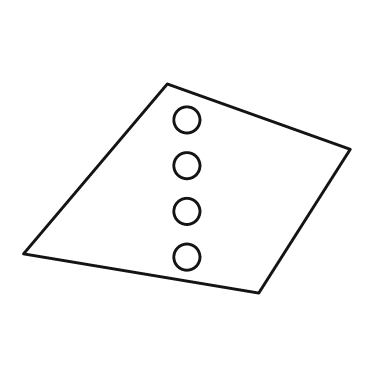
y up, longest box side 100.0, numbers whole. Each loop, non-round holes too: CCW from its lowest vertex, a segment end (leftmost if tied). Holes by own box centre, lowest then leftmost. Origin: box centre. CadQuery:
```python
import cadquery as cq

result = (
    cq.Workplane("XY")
    .moveTo(22.0, -32.0)
    .lineTo(50.0, 12.0)
    .lineTo(-6.0, 32.0)
    .lineTo(-50.0, -20.0)
    .close()
    .moveTo(0.0, -21.0)
    .circle(4.0)
    .moveTo(0.0, -7.0)
    .circle(4.0)
    .moveTo(0.0, 7.0)
    .circle(4.0)
    .moveTo(0.0, 21.0)
    .circle(4.0)
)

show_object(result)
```